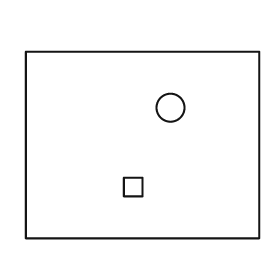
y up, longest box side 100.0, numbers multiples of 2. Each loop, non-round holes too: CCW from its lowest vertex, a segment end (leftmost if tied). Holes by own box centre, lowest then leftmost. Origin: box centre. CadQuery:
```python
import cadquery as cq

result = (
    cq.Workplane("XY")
    .moveTo(-50.0, -40.0)
    .lineTo(50.0, -40.0)
    .lineTo(50.0, 40.0)
    .lineTo(-50.0, 40.0)
    .close()
    .moveTo(-8.0, -22.0)
    .lineTo(0.0, -22.0)
    .lineTo(0.0, -14.0)
    .lineTo(-8.0, -14.0)
    .close()
    .moveTo(12.0, 16.0)
    .circle(6.0)
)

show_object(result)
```